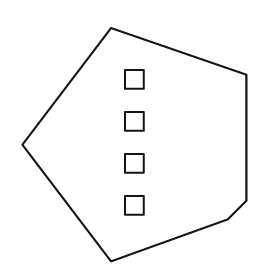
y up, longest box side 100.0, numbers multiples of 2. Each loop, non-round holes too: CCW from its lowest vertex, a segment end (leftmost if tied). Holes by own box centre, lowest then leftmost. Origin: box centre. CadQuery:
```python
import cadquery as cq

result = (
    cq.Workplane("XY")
    .moveTo(-10.0, -50.0)
    .lineTo(40.0, -32.0)
    .lineTo(48.0, -24.0)
    .lineTo(48.0, 30.0)
    .lineTo(-10.0, 50.0)
    .lineTo(-48.0, 0.0)
    .close()
    .moveTo(-4.0, -30.0)
    .lineTo(4.0, -30.0)
    .lineTo(4.0, -22.0)
    .lineTo(-4.0, -22.0)
    .close()
    .moveTo(-4.0, -12.0)
    .lineTo(4.0, -12.0)
    .lineTo(4.0, -4.0)
    .lineTo(-4.0, -4.0)
    .close()
    .moveTo(-4.0, 6.0)
    .lineTo(4.0, 6.0)
    .lineTo(4.0, 14.0)
    .lineTo(-4.0, 14.0)
    .close()
    .moveTo(-4.0, 24.0)
    .lineTo(4.0, 24.0)
    .lineTo(4.0, 32.0)
    .lineTo(-4.0, 32.0)
    .close()
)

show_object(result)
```